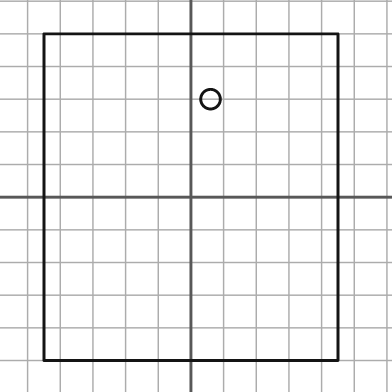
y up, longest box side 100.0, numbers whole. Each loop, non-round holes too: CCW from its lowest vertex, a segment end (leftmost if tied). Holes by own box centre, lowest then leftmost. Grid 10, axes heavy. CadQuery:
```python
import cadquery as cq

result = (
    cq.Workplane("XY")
    .moveTo(-45.0, -50.0)
    .lineTo(45.0, -50.0)
    .lineTo(45.0, 50.0)
    .lineTo(-45.0, 50.0)
    .close()
    .moveTo(6.0, 30.0)
    .circle(3.0)
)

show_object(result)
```